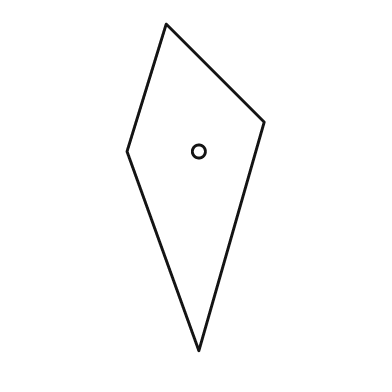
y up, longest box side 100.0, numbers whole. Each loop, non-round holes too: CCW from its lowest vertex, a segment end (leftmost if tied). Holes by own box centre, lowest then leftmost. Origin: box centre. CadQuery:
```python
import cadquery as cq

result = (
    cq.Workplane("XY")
    .moveTo(1.0, -50.0)
    .lineTo(21.0, 20.0)
    .lineTo(-9.0, 50.0)
    .lineTo(-21.0, 11.0)
    .close()
    .moveTo(1.0, 11.0)
    .circle(2.0)
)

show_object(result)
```